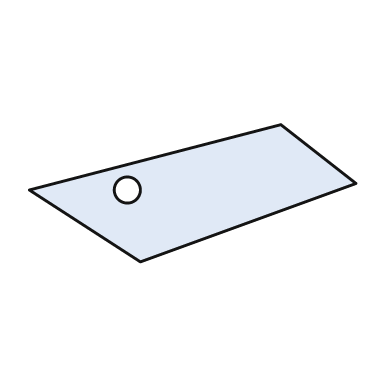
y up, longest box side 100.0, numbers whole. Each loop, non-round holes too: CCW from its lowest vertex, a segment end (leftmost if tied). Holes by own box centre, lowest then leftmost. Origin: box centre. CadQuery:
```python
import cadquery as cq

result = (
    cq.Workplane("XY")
    .moveTo(-16.0, -21.0)
    .lineTo(50.0, 3.0)
    .lineTo(27.0, 21.0)
    .lineTo(-50.0, 1.0)
    .close()
    .moveTo(-20.0, 1.0)
    .circle(4.0)
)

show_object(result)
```